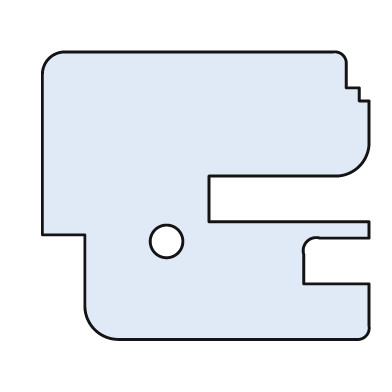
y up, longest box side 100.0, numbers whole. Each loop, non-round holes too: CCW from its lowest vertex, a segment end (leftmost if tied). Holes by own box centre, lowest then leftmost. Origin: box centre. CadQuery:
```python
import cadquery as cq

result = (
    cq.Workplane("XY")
    .moveTo(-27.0, -44.0)
    .lineTo(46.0, -44.0)
    .threePointArc((49.0, -43.0), (50.0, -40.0))
    .lineTo(50.0, -27.0)
    .lineTo(30.0, -27.0)
    .lineTo(30.0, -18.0)
    .threePointArc((31.0, -14.0), (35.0, -13.0))
    .lineTo(50.0, -13.0)
    .lineTo(50.0, -8.0)
    .lineTo(1.0, -8.0)
    .lineTo(1.0, 6.0)
    .lineTo(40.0, 6.0)
    .threePointArc((47.0, 9.0), (50.0, 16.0))
    .lineTo(50.0, 29.0)
    .lineTo(47.0, 29.0)
    .lineTo(47.0, 33.0)
    .lineTo(43.0, 33.0)
    .lineTo(43.0, 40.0)
    .threePointArc((42.0, 43.0), (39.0, 44.0))
    .lineTo(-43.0, 44.0)
    .threePointArc((-48.0, 42.0), (-50.0, 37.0))
    .lineTo(-50.0, -12.0)
    .lineTo(-37.0, -12.0)
    .lineTo(-37.0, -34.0)
    .threePointArc((-34.0, -41.0), (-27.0, -44.0))
    .close()
    .moveTo(-12.0, -14.0)
    .circle(5.0)
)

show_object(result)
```